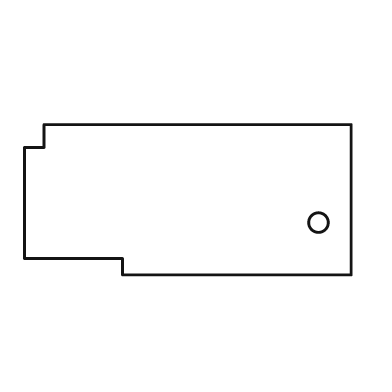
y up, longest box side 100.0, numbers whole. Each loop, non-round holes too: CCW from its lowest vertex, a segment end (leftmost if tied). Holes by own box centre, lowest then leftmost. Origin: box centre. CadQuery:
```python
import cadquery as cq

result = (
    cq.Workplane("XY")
    .moveTo(-20.0, -23.0)
    .lineTo(50.0, -23.0)
    .lineTo(50.0, 23.0)
    .lineTo(-44.0, 23.0)
    .lineTo(-44.0, 16.0)
    .lineTo(-50.0, 16.0)
    .lineTo(-50.0, -18.0)
    .lineTo(-20.0, -18.0)
    .close()
    .moveTo(40.0, -7.0)
    .circle(3.0)
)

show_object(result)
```